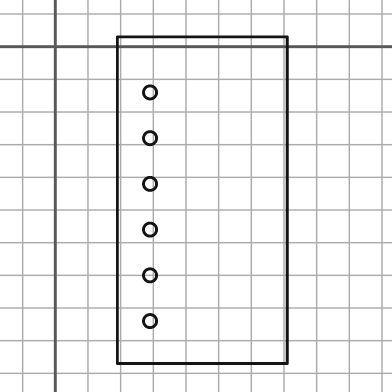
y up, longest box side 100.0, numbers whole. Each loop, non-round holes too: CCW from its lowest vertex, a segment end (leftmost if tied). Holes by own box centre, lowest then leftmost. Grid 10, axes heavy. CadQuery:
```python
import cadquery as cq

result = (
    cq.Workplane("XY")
    .moveTo(19.0, -97.0)
    .lineTo(71.0, -97.0)
    .lineTo(71.0, 3.0)
    .lineTo(19.0, 3.0)
    .close()
    .moveTo(29.0, -84.0)
    .circle(2.0)
    .moveTo(29.0, -70.0)
    .circle(2.0)
    .moveTo(29.0, -56.0)
    .circle(2.0)
    .moveTo(29.0, -42.0)
    .circle(2.0)
    .moveTo(29.0, -28.0)
    .circle(2.0)
    .moveTo(29.0, -14.0)
    .circle(2.0)
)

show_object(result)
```